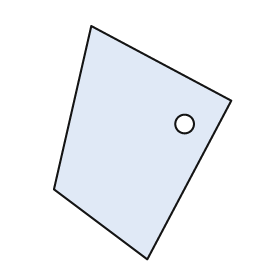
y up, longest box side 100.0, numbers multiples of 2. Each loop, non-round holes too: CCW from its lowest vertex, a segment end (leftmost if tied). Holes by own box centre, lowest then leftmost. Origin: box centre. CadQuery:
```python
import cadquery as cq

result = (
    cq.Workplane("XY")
    .moveTo(2.0, -50.0)
    .lineTo(38.0, 18.0)
    .lineTo(-22.0, 50.0)
    .lineTo(-38.0, -20.0)
    .close()
    .moveTo(18.0, 8.0)
    .circle(4.0)
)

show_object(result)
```